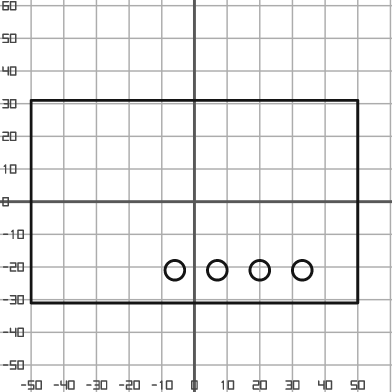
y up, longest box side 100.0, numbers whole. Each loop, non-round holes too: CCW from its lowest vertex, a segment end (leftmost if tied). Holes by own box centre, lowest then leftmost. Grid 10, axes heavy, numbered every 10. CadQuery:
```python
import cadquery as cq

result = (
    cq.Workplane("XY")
    .moveTo(-50.0, -31.0)
    .lineTo(50.0, -31.0)
    .lineTo(50.0, 31.0)
    .lineTo(-50.0, 31.0)
    .close()
    .moveTo(-6.0, -21.0)
    .circle(3.0)
    .moveTo(7.0, -21.0)
    .circle(3.0)
    .moveTo(20.0, -21.0)
    .circle(3.0)
    .moveTo(33.0, -21.0)
    .circle(3.0)
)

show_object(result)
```